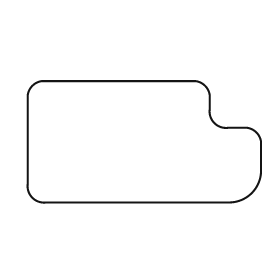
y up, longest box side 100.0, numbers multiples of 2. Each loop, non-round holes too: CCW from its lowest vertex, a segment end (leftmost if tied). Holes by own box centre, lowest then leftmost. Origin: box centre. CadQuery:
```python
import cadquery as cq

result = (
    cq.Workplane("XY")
    .moveTo(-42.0, -26.0)
    .lineTo(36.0, -26.0)
    .threePointArc((46.0, -22.0), (50.0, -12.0))
    .lineTo(50.0, 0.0)
    .threePointArc((48.0, 4.0), (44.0, 6.0))
    .lineTo(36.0, 6.0)
    .threePointArc((30.0, 8.0), (28.0, 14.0))
    .lineTo(28.0, 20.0)
    .threePointArc((26.0, 24.0), (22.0, 26.0))
    .lineTo(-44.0, 26.0)
    .threePointArc((-48.0, 24.0), (-50.0, 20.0))
    .lineTo(-50.0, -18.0)
    .threePointArc((-48.0, -24.0), (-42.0, -26.0))
    .close()
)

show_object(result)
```